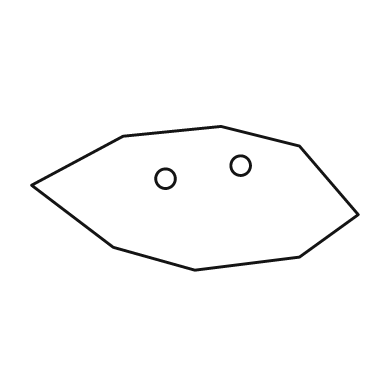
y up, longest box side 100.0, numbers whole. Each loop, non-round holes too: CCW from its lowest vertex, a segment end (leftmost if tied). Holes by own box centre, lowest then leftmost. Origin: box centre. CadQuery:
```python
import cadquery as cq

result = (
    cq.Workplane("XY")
    .moveTo(0.0, -22.0)
    .lineTo(32.0, -18.0)
    .lineTo(50.0, -5.0)
    .lineTo(32.0, 16.0)
    .lineTo(8.0, 22.0)
    .lineTo(-22.0, 19.0)
    .lineTo(-50.0, 4.0)
    .lineTo(-25.0, -15.0)
    .close()
    .moveTo(-9.0, 6.0)
    .circle(3.0)
    .moveTo(14.0, 10.0)
    .circle(3.0)
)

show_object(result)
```